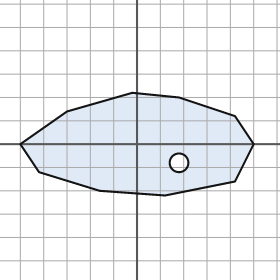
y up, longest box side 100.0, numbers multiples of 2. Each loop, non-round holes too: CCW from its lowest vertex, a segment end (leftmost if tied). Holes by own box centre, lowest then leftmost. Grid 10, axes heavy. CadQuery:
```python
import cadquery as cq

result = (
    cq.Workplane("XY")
    .moveTo(12.0, -22.0)
    .lineTo(42.0, -16.0)
    .lineTo(50.0, 0.0)
    .lineTo(42.0, 12.0)
    .lineTo(18.0, 20.0)
    .lineTo(-2.0, 22.0)
    .lineTo(-30.0, 14.0)
    .lineTo(-50.0, 0.0)
    .lineTo(-42.0, -12.0)
    .lineTo(-16.0, -20.0)
    .close()
    .moveTo(18.0, -8.0)
    .circle(4.0)
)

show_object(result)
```